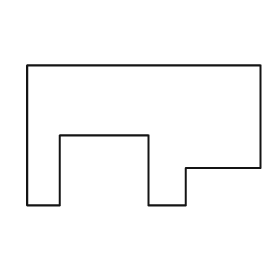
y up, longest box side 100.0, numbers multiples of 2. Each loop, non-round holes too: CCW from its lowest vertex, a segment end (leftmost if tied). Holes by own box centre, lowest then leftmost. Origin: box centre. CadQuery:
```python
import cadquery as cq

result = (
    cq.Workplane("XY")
    .moveTo(-50.0, -30.0)
    .lineTo(-36.0, -30.0)
    .lineTo(-36.0, 0.0)
    .lineTo(2.0, 0.0)
    .lineTo(2.0, -30.0)
    .lineTo(18.0, -30.0)
    .lineTo(18.0, -14.0)
    .lineTo(50.0, -14.0)
    .lineTo(50.0, 30.0)
    .lineTo(-50.0, 30.0)
    .close()
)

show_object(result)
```